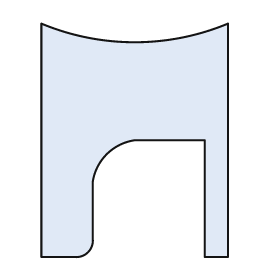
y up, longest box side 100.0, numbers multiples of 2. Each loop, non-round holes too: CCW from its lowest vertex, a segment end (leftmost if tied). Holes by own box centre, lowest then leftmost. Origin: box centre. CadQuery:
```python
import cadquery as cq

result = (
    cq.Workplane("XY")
    .moveTo(-40.0, -50.0)
    .lineTo(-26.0, -50.0)
    .threePointArc((-20.0, -48.0), (-18.0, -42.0))
    .lineTo(-18.0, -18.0)
    .threePointArc((-12.0, -6.0), (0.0, 0.0))
    .lineTo(30.0, 0.0)
    .lineTo(30.0, -50.0)
    .lineTo(40.0, -50.0)
    .lineTo(40.0, 50.0)
    .threePointArc((0.0, 42.0), (-40.0, 50.0))
    .close()
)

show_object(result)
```